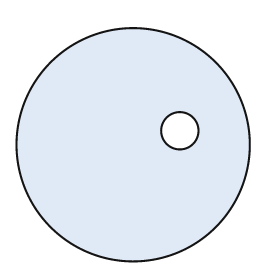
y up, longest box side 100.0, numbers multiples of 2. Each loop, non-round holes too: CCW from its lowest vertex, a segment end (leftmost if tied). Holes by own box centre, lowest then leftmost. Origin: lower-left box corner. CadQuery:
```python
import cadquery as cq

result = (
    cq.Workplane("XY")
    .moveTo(50.0, 50.0)
    .circle(50.0)
    .moveTo(70.0, 56.0)
    .circle(8.0)
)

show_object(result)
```